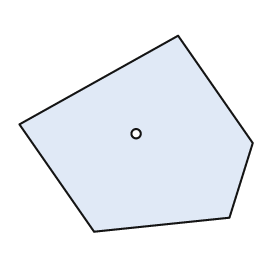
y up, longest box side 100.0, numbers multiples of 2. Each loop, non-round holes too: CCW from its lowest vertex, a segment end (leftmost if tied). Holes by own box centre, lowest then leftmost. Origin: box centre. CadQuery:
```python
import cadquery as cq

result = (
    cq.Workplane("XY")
    .moveTo(-18.0, -42.0)
    .lineTo(40.0, -36.0)
    .lineTo(50.0, -4.0)
    .lineTo(18.0, 42.0)
    .lineTo(-50.0, 4.0)
    .close()
    .moveTo(0.0, 0.0)
    .circle(2.0)
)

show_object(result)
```